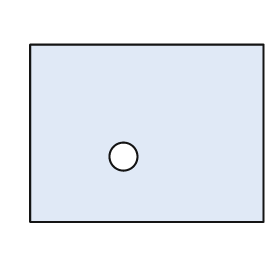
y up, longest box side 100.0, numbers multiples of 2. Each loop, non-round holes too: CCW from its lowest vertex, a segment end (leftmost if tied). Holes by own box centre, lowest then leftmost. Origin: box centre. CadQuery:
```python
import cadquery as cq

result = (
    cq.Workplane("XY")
    .moveTo(-50.0, -38.0)
    .lineTo(50.0, -38.0)
    .lineTo(50.0, 38.0)
    .lineTo(-50.0, 38.0)
    .close()
    .moveTo(-10.0, -10.0)
    .circle(6.0)
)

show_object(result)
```